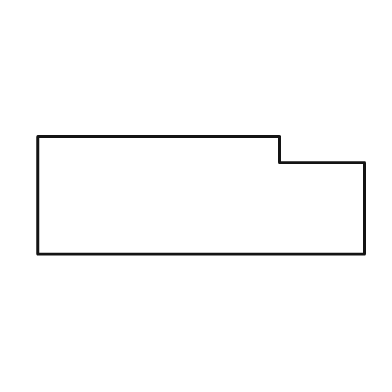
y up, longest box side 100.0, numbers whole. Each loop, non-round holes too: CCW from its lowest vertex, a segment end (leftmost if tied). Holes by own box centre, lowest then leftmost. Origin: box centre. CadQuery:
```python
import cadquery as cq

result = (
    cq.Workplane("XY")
    .moveTo(-50.0, -18.0)
    .lineTo(50.0, -18.0)
    .lineTo(50.0, 10.0)
    .lineTo(24.0, 10.0)
    .lineTo(24.0, 18.0)
    .lineTo(-50.0, 18.0)
    .close()
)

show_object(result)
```